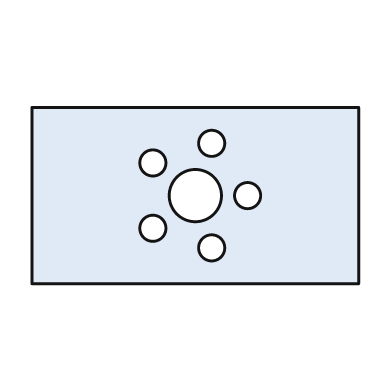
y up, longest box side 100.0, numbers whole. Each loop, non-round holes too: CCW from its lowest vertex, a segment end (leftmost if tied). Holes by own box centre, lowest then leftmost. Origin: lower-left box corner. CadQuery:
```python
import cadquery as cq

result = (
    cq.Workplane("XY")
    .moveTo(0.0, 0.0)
    .lineTo(100.0, 0.0)
    .lineTo(100.0, 54.0)
    .lineTo(0.0, 54.0)
    .close()
    .moveTo(55.0, 11.0)
    .circle(4.0)
    .moveTo(37.0, 17.0)
    .circle(4.0)
    .moveTo(50.0, 27.0)
    .circle(8.0)
    .moveTo(66.0, 27.0)
    .circle(4.0)
    .moveTo(37.0, 37.0)
    .circle(4.0)
    .moveTo(55.0, 43.0)
    .circle(4.0)
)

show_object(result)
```